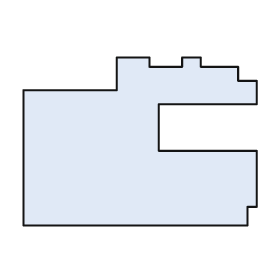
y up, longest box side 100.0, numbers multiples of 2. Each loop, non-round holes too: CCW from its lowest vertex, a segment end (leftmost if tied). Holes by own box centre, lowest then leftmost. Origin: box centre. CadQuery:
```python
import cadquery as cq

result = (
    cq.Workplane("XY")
    .moveTo(-50.0, -36.0)
    .lineTo(46.0, -36.0)
    .lineTo(46.0, -28.0)
    .lineTo(50.0, -28.0)
    .lineTo(50.0, -4.0)
    .lineTo(8.0, -4.0)
    .lineTo(8.0, 16.0)
    .lineTo(50.0, 16.0)
    .lineTo(50.0, 26.0)
    .lineTo(42.0, 26.0)
    .lineTo(42.0, 32.0)
    .lineTo(26.0, 32.0)
    .lineTo(26.0, 36.0)
    .lineTo(18.0, 36.0)
    .lineTo(18.0, 32.0)
    .lineTo(4.0, 32.0)
    .lineTo(4.0, 36.0)
    .lineTo(-10.0, 36.0)
    .lineTo(-10.0, 22.0)
    .lineTo(-50.0, 22.0)
    .close()
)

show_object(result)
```